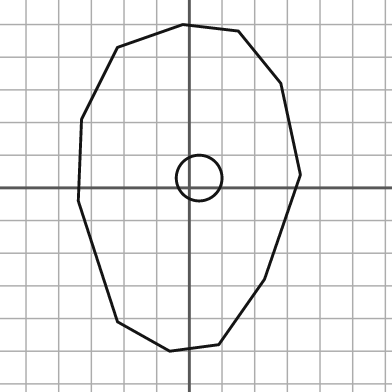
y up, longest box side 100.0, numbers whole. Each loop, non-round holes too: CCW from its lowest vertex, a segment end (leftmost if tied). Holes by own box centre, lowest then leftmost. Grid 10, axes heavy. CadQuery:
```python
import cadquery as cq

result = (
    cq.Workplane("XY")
    .moveTo(-6.0, -50.0)
    .lineTo(9.0, -48.0)
    .lineTo(23.0, -28.0)
    .lineTo(34.0, 4.0)
    .lineTo(28.0, 32.0)
    .lineTo(15.0, 48.0)
    .lineTo(-2.0, 50.0)
    .lineTo(-22.0, 43.0)
    .lineTo(-33.0, 21.0)
    .lineTo(-34.0, -4.0)
    .lineTo(-22.0, -41.0)
    .close()
    .moveTo(3.0, 3.0)
    .circle(7.0)
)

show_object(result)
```